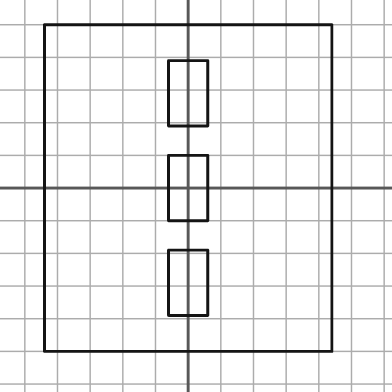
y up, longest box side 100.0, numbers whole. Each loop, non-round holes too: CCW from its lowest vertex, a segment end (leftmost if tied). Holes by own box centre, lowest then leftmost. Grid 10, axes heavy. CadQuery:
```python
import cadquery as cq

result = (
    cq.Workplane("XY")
    .moveTo(-44.0, -50.0)
    .lineTo(44.0, -50.0)
    .lineTo(44.0, 50.0)
    .lineTo(-44.0, 50.0)
    .close()
    .moveTo(-6.0, -39.0)
    .lineTo(6.0, -39.0)
    .lineTo(6.0, -19.0)
    .lineTo(-6.0, -19.0)
    .close()
    .moveTo(-6.0, -10.0)
    .lineTo(6.0, -10.0)
    .lineTo(6.0, 10.0)
    .lineTo(-6.0, 10.0)
    .close()
    .moveTo(-6.0, 19.0)
    .lineTo(6.0, 19.0)
    .lineTo(6.0, 39.0)
    .lineTo(-6.0, 39.0)
    .close()
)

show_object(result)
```